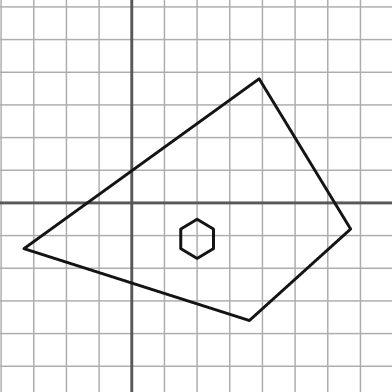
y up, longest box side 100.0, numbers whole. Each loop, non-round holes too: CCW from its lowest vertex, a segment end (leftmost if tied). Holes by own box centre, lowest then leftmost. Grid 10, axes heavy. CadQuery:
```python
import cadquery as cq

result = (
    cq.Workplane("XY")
    .moveTo(36.0, -36.0)
    .lineTo(67.0, -8.0)
    .lineTo(39.0, 38.0)
    .lineTo(-33.0, -14.0)
    .close()
    .moveTo(20.0, -17.0)
    .lineTo(25.0, -14.0)
    .lineTo(25.0, -8.0)
    .lineTo(20.0, -5.0)
    .lineTo(15.0, -8.0)
    .lineTo(15.0, -14.0)
    .close()
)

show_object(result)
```